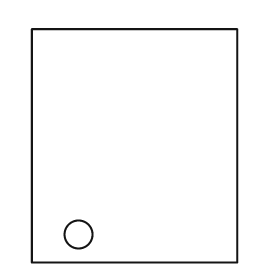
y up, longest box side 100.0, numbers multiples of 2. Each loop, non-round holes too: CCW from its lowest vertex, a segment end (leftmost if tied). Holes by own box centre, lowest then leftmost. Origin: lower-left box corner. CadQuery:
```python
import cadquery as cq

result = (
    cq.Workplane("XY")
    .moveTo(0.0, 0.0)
    .lineTo(88.0, 0.0)
    .lineTo(88.0, 100.0)
    .lineTo(0.0, 100.0)
    .close()
    .moveTo(20.0, 12.0)
    .circle(6.0)
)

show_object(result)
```